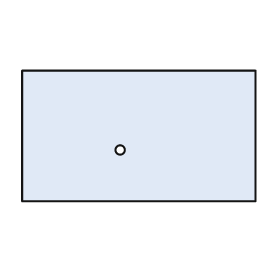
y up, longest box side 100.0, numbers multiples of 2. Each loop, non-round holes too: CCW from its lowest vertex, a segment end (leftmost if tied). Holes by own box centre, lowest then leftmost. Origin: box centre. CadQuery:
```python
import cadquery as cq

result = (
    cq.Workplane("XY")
    .moveTo(-50.0, -28.0)
    .lineTo(50.0, -28.0)
    .lineTo(50.0, 28.0)
    .lineTo(-50.0, 28.0)
    .close()
    .moveTo(-8.0, -6.0)
    .circle(2.0)
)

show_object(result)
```